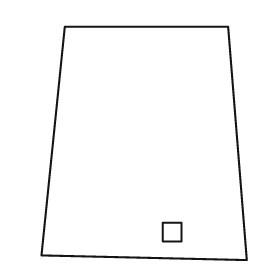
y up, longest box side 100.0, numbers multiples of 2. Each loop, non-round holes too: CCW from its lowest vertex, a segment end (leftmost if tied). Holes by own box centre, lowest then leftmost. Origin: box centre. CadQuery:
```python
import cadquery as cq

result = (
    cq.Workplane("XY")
    .moveTo(44.0, -50.0)
    .lineTo(36.0, 50.0)
    .lineTo(-34.0, 50.0)
    .lineTo(-44.0, -48.0)
    .close()
    .moveTo(8.0, -42.0)
    .lineTo(16.0, -42.0)
    .lineTo(16.0, -34.0)
    .lineTo(8.0, -34.0)
    .close()
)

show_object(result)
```